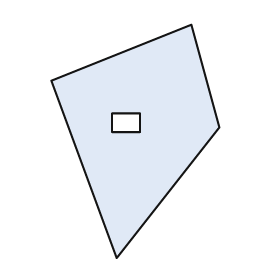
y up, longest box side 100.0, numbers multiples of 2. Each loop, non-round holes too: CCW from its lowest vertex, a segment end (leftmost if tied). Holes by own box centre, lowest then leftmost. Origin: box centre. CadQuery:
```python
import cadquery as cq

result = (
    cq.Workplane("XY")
    .moveTo(-8.0, -50.0)
    .lineTo(36.0, 6.0)
    .lineTo(24.0, 50.0)
    .lineTo(-36.0, 26.0)
    .close()
    .moveTo(-10.0, 4.0)
    .lineTo(2.0, 4.0)
    .lineTo(2.0, 12.0)
    .lineTo(-10.0, 12.0)
    .close()
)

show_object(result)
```